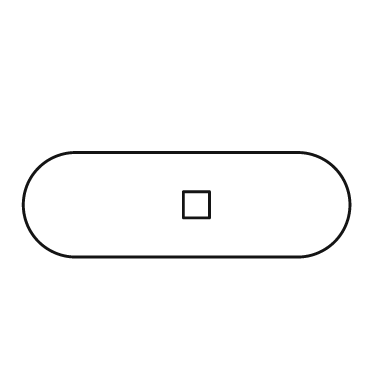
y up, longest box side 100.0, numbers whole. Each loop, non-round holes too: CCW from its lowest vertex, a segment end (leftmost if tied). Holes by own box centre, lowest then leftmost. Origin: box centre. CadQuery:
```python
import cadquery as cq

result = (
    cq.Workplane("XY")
    .moveTo(-34.0, -16.0)
    .lineTo(34.0, -16.0)
    .threePointArc((50.0, 0.0), (34.0, 16.0))
    .lineTo(-34.0, 16.0)
    .threePointArc((-50.0, 0.0), (-34.0, -16.0))
    .close()
    .moveTo(-1.0, -4.0)
    .lineTo(7.0, -4.0)
    .lineTo(7.0, 4.0)
    .lineTo(-1.0, 4.0)
    .close()
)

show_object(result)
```